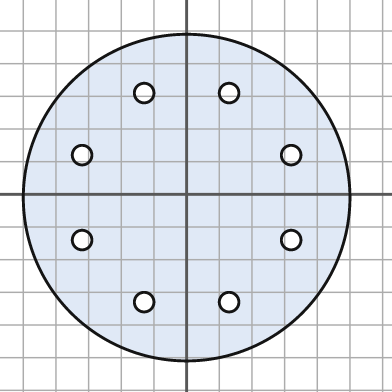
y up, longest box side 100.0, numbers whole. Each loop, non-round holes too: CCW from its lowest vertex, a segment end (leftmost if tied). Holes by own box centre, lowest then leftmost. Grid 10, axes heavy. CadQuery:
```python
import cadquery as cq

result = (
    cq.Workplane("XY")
    .moveTo(0.0, -1.0)
    .circle(50.0)
    .moveTo(-13.0, -33.0)
    .circle(3.0)
    .moveTo(13.0, -33.0)
    .circle(3.0)
    .moveTo(-32.0, -14.0)
    .circle(3.0)
    .moveTo(32.0, -14.0)
    .circle(3.0)
    .moveTo(-32.0, 12.0)
    .circle(3.0)
    .moveTo(32.0, 12.0)
    .circle(3.0)
    .moveTo(-13.0, 31.0)
    .circle(3.0)
    .moveTo(13.0, 31.0)
    .circle(3.0)
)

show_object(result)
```